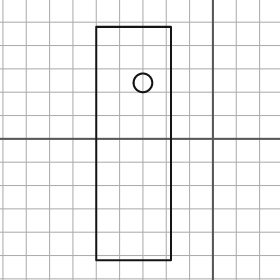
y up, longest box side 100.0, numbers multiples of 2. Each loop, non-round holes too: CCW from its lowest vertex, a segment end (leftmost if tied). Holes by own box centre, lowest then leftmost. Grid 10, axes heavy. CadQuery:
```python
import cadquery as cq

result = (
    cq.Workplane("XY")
    .moveTo(-50.0, -52.0)
    .lineTo(-18.0, -52.0)
    .lineTo(-18.0, 48.0)
    .lineTo(-50.0, 48.0)
    .close()
    .moveTo(-30.0, 24.0)
    .circle(4.0)
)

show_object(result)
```